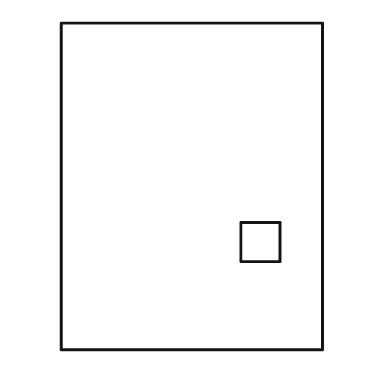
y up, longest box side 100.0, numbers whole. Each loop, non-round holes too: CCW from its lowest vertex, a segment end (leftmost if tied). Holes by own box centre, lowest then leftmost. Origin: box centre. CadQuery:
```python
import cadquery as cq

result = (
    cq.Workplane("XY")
    .moveTo(-40.0, -50.0)
    .lineTo(40.0, -50.0)
    .lineTo(40.0, 50.0)
    .lineTo(-40.0, 50.0)
    .close()
    .moveTo(15.0, -23.0)
    .lineTo(27.0, -23.0)
    .lineTo(27.0, -11.0)
    .lineTo(15.0, -11.0)
    .close()
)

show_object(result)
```